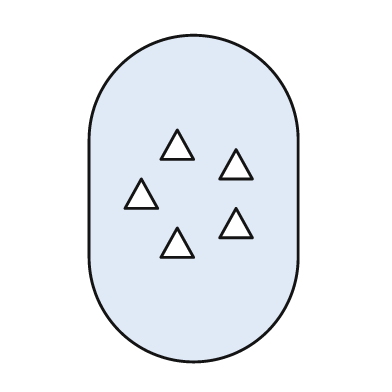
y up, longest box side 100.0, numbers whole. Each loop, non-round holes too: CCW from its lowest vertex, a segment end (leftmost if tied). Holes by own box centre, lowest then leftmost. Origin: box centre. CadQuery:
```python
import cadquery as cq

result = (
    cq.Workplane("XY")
    .moveTo(-32.0, -18.0)
    .threePointArc((0.0, -50.0), (32.0, -18.0))
    .lineTo(32.0, 18.0)
    .threePointArc((0.0, 50.0), (-32.0, 18.0))
    .close()
    .moveTo(-10.0, -18.0)
    .lineTo(0.0, -18.0)
    .lineTo(-5.0, -9.0)
    .close()
    .moveTo(8.0, -12.0)
    .lineTo(18.0, -12.0)
    .lineTo(13.0, -3.0)
    .close()
    .moveTo(-21.0, -3.0)
    .lineTo(-11.0, -3.0)
    .lineTo(-16.0, 6.0)
    .close()
    .moveTo(8.0, 6.0)
    .lineTo(18.0, 6.0)
    .lineTo(13.0, 15.0)
    .close()
    .moveTo(-10.0, 12.0)
    .lineTo(0.0, 12.0)
    .lineTo(-5.0, 21.0)
    .close()
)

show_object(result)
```